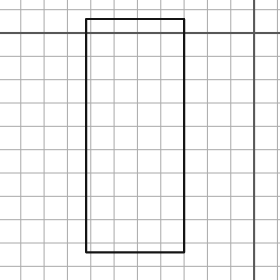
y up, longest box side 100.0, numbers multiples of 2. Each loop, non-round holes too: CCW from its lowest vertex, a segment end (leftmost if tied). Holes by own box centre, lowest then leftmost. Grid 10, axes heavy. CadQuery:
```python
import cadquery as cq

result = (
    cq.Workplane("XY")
    .moveTo(-72.0, -94.0)
    .lineTo(-30.0, -94.0)
    .lineTo(-30.0, 6.0)
    .lineTo(-72.0, 6.0)
    .close()
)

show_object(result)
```